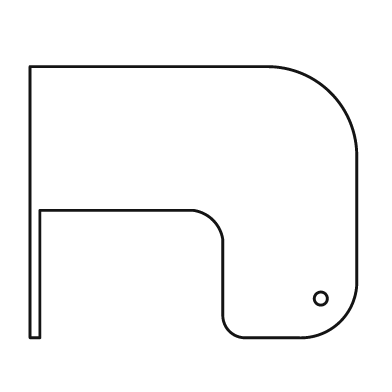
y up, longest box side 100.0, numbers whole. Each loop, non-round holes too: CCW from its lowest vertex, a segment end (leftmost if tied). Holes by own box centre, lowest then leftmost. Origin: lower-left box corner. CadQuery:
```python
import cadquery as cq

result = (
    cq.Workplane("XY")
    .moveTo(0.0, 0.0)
    .lineTo(3.0, 0.0)
    .lineTo(3.0, 39.0)
    .lineTo(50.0, 39.0)
    .threePointArc((56.0, 36.0), (59.0, 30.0))
    .lineTo(59.0, 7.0)
    .threePointArc((61.0, 2.0), (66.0, 0.0))
    .lineTo(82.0, 0.0)
    .threePointArc((95.0, 5.0), (100.0, 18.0))
    .lineTo(100.0, 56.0)
    .threePointArc((92.0, 75.0), (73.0, 83.0))
    .lineTo(0.0, 83.0)
    .close()
    .moveTo(89.0, 12.0)
    .circle(2.0)
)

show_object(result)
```